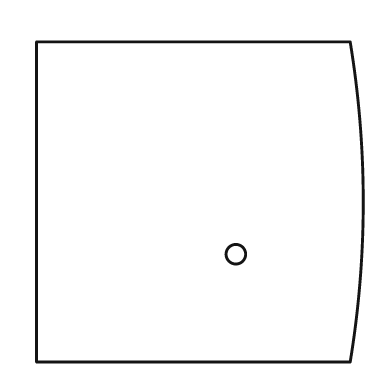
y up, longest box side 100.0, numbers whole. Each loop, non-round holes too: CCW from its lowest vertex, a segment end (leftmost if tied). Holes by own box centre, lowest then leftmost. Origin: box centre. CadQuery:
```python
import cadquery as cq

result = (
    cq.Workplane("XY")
    .moveTo(-50.0, -49.0)
    .lineTo(46.0, -49.0)
    .threePointArc((50.0, 0.0), (46.0, 49.0))
    .lineTo(-50.0, 49.0)
    .close()
    .moveTo(11.0, -16.0)
    .circle(3.0)
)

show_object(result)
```